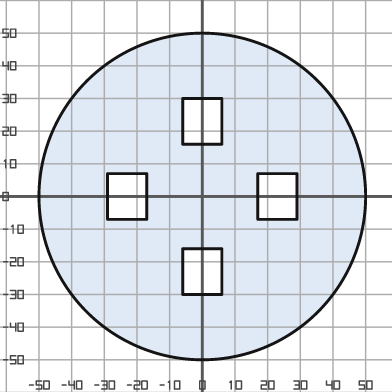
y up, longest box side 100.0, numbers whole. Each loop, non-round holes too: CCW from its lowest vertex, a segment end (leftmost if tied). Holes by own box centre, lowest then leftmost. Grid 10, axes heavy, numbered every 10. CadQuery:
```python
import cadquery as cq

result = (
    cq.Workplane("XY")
    .moveTo(0.0, 0.0)
    .circle(50.0)
    .moveTo(-6.0, -30.0)
    .lineTo(6.0, -30.0)
    .lineTo(6.0, -16.0)
    .lineTo(-6.0, -16.0)
    .close()
    .moveTo(-29.0, -7.0)
    .lineTo(-17.0, -7.0)
    .lineTo(-17.0, 7.0)
    .lineTo(-29.0, 7.0)
    .close()
    .moveTo(17.0, -7.0)
    .lineTo(29.0, -7.0)
    .lineTo(29.0, 7.0)
    .lineTo(17.0, 7.0)
    .close()
    .moveTo(-6.0, 16.0)
    .lineTo(6.0, 16.0)
    .lineTo(6.0, 30.0)
    .lineTo(-6.0, 30.0)
    .close()
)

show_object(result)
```